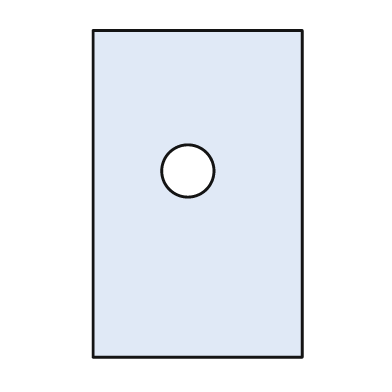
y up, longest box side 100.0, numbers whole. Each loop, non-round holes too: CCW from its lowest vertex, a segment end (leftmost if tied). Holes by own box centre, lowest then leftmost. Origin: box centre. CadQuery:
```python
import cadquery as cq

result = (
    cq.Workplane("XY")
    .moveTo(-32.0, -50.0)
    .lineTo(32.0, -50.0)
    .lineTo(32.0, 50.0)
    .lineTo(-32.0, 50.0)
    .close()
    .moveTo(-3.0, 7.0)
    .circle(8.0)
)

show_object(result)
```